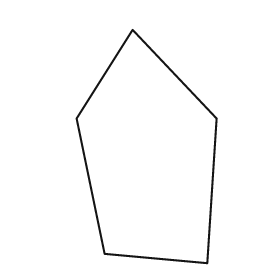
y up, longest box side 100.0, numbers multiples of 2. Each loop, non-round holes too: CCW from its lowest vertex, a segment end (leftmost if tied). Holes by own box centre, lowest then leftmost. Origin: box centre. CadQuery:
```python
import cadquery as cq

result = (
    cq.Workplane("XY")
    .moveTo(26.0, -50.0)
    .lineTo(30.0, 12.0)
    .lineTo(-6.0, 50.0)
    .lineTo(-30.0, 12.0)
    .lineTo(-18.0, -46.0)
    .close()
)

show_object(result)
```